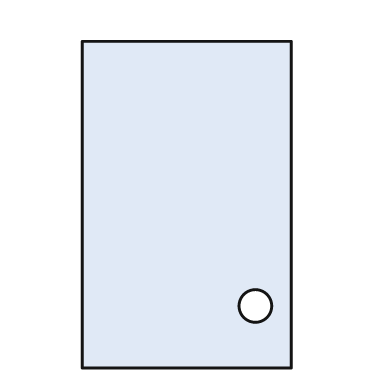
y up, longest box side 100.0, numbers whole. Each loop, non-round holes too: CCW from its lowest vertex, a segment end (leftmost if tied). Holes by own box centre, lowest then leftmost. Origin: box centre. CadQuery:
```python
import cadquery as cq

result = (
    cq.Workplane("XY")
    .moveTo(-32.0, -50.0)
    .lineTo(32.0, -50.0)
    .lineTo(32.0, 50.0)
    .lineTo(-32.0, 50.0)
    .close()
    .moveTo(21.0, -31.0)
    .circle(5.0)
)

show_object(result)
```